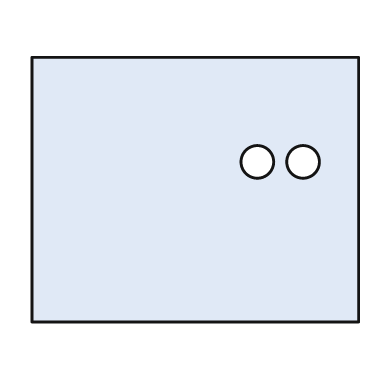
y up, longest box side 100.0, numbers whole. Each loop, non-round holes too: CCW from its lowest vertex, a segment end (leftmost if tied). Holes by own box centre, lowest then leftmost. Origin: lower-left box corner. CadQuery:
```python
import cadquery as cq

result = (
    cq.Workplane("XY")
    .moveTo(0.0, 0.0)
    .lineTo(100.0, 0.0)
    .lineTo(100.0, 81.0)
    .lineTo(0.0, 81.0)
    .close()
    .moveTo(69.0, 49.0)
    .circle(5.0)
    .moveTo(83.0, 49.0)
    .circle(5.0)
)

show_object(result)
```